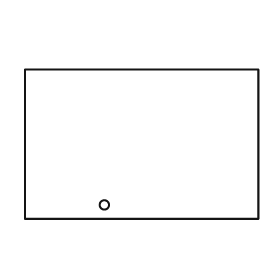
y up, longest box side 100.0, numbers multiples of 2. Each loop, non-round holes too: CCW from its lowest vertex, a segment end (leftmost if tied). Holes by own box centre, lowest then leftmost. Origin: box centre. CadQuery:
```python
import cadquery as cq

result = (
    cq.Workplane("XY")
    .moveTo(-50.0, -32.0)
    .lineTo(50.0, -32.0)
    .lineTo(50.0, 32.0)
    .lineTo(-50.0, 32.0)
    .close()
    .moveTo(-16.0, -26.0)
    .circle(2.0)
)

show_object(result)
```